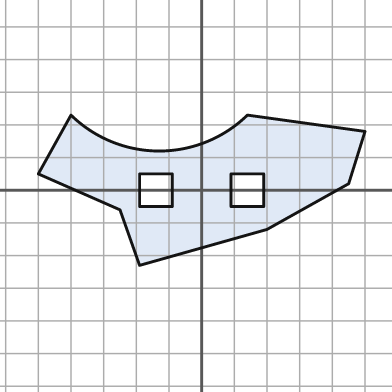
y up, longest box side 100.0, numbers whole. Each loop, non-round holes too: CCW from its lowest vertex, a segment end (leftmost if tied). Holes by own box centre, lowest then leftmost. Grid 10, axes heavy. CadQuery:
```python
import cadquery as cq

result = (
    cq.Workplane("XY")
    .moveTo(-19.0, -23.0)
    .lineTo(20.0, -12.0)
    .lineTo(45.0, 2.0)
    .lineTo(50.0, 18.0)
    .lineTo(14.0, 23.0)
    .threePointArc((-13.0, 12.0), (-40.0, 23.0))
    .lineTo(-50.0, 5.0)
    .lineTo(-25.0, -6.0)
    .close()
    .moveTo(-19.0, -5.0)
    .lineTo(-9.0, -5.0)
    .lineTo(-9.0, 5.0)
    .lineTo(-19.0, 5.0)
    .close()
    .moveTo(9.0, -5.0)
    .lineTo(19.0, -5.0)
    .lineTo(19.0, 5.0)
    .lineTo(9.0, 5.0)
    .close()
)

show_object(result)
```